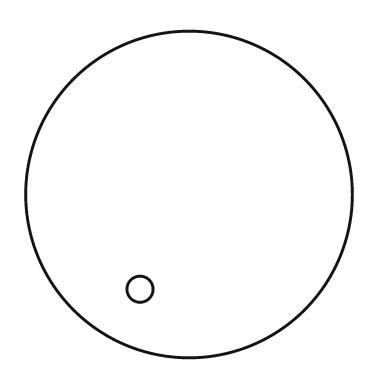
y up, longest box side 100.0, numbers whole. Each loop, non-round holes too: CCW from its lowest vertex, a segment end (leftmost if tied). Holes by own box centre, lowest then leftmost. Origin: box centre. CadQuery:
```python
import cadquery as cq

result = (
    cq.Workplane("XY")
    .moveTo(0.0, 0.0)
    .circle(50.0)
    .moveTo(-15.0, -29.0)
    .circle(4.0)
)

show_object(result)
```